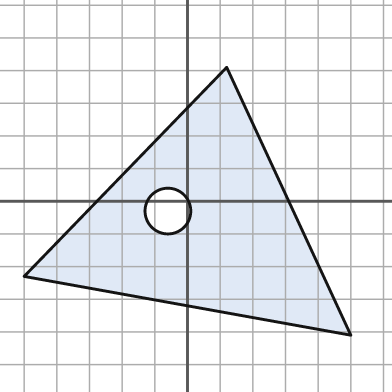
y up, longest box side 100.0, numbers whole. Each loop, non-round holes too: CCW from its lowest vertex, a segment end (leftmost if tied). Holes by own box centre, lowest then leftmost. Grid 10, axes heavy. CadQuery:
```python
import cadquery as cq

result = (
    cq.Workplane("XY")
    .moveTo(50.0, -41.0)
    .lineTo(12.0, 41.0)
    .lineTo(-50.0, -23.0)
    .close()
    .moveTo(-6.0, -3.0)
    .circle(7.0)
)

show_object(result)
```